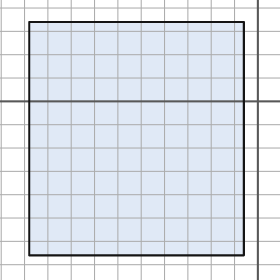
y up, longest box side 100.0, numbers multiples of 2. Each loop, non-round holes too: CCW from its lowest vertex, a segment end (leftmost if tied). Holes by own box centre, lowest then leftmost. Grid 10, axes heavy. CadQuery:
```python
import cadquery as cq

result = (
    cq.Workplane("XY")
    .moveTo(-98.0, -66.0)
    .lineTo(-6.0, -66.0)
    .lineTo(-6.0, 34.0)
    .lineTo(-98.0, 34.0)
    .close()
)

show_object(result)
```